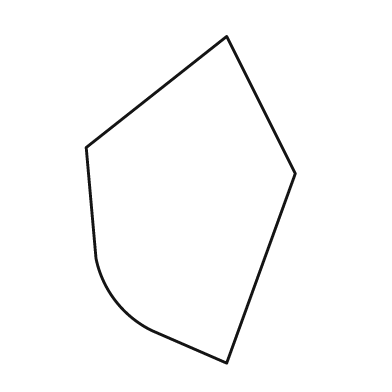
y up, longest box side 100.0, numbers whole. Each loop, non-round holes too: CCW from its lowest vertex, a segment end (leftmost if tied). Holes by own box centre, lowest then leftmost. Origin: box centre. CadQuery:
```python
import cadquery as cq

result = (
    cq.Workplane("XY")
    .moveTo(11.0, -50.0)
    .lineTo(32.0, 8.0)
    .lineTo(11.0, 50.0)
    .lineTo(-32.0, 16.0)
    .lineTo(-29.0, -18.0)
    .threePointArc((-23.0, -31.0), (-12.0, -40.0))
    .close()
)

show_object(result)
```